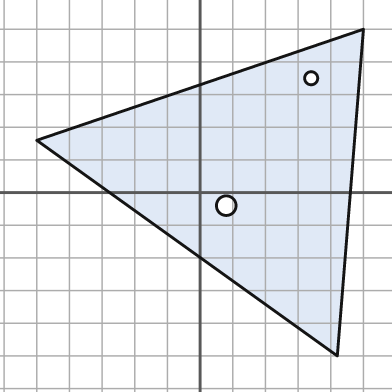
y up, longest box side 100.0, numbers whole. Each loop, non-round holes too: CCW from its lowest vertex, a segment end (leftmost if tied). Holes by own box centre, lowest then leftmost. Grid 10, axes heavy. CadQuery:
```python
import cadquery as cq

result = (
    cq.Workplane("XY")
    .moveTo(42.0, -50.0)
    .lineTo(50.0, 50.0)
    .lineTo(-50.0, 16.0)
    .close()
    .moveTo(8.0, -4.0)
    .circle(3.0)
    .moveTo(34.0, 35.0)
    .circle(2.0)
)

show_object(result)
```